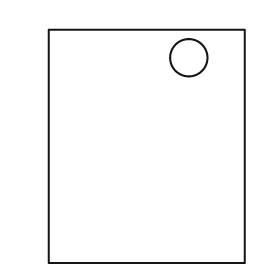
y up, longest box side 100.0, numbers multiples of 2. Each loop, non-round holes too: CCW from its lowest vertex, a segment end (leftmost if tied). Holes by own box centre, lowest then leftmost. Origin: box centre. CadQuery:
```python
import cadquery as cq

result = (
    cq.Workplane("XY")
    .moveTo(-42.0, -50.0)
    .lineTo(42.0, -50.0)
    .lineTo(42.0, 50.0)
    .lineTo(-42.0, 50.0)
    .close()
    .moveTo(18.0, 38.0)
    .circle(8.0)
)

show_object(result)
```